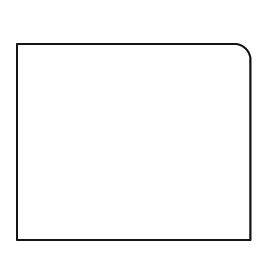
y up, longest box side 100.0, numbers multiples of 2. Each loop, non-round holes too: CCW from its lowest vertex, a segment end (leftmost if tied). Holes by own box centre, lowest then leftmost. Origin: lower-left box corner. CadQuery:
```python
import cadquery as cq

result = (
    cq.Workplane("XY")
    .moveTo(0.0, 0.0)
    .lineTo(100.0, 0.0)
    .lineTo(100.0, 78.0)
    .threePointArc((98.0, 82.0), (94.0, 84.0))
    .lineTo(0.0, 84.0)
    .close()
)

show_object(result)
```